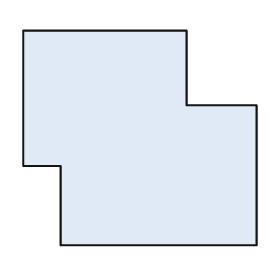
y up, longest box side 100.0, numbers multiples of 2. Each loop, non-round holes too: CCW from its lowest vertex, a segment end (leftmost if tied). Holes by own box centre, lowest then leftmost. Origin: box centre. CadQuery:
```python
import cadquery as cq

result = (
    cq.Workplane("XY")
    .moveTo(-34.0, -46.0)
    .lineTo(50.0, -46.0)
    .lineTo(50.0, 14.0)
    .lineTo(20.0, 14.0)
    .lineTo(20.0, 46.0)
    .lineTo(-50.0, 46.0)
    .lineTo(-50.0, -12.0)
    .lineTo(-34.0, -12.0)
    .close()
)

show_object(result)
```